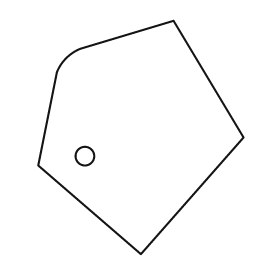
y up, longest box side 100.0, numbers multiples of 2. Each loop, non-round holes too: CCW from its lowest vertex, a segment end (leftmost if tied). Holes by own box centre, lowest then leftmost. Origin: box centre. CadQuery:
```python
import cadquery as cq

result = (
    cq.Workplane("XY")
    .moveTo(0.0, -50.0)
    .lineTo(44.0, 0.0)
    .lineTo(14.0, 50.0)
    .lineTo(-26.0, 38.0)
    .threePointArc((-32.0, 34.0), (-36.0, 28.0))
    .lineTo(-44.0, -12.0)
    .close()
    .moveTo(-24.0, -8.0)
    .circle(4.0)
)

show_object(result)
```